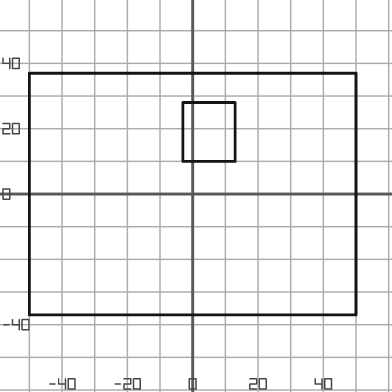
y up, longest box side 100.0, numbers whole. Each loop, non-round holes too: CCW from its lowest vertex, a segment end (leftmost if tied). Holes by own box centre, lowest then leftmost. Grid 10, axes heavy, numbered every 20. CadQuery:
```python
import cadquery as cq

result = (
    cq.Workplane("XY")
    .moveTo(-50.0, -37.0)
    .lineTo(50.0, -37.0)
    .lineTo(50.0, 37.0)
    .lineTo(-50.0, 37.0)
    .close()
    .moveTo(-3.0, 10.0)
    .lineTo(13.0, 10.0)
    .lineTo(13.0, 28.0)
    .lineTo(-3.0, 28.0)
    .close()
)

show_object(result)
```